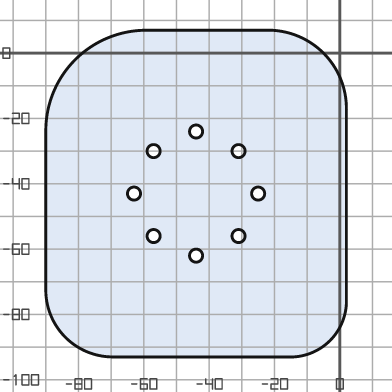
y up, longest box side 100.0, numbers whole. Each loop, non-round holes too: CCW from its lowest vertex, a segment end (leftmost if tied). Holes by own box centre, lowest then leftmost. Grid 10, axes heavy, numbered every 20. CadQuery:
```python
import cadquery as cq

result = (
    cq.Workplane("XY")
    .moveTo(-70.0, -93.0)
    .lineTo(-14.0, -93.0)
    .threePointArc((-3.0, -88.0), (2.0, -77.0))
    .lineTo(2.0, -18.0)
    .threePointArc((-5.0, 0.0), (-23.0, 7.0))
    .lineTo(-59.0, 7.0)
    .threePointArc((-81.0, -2.0), (-90.0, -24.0))
    .lineTo(-90.0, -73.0)
    .threePointArc((-84.0, -87.0), (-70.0, -93.0))
    .close()
    .moveTo(-44.0, -62.0)
    .circle(2.0)
    .moveTo(-57.0, -56.0)
    .circle(2.0)
    .moveTo(-31.0, -56.0)
    .circle(2.0)
    .moveTo(-63.0, -43.0)
    .circle(2.0)
    .moveTo(-25.0, -43.0)
    .circle(2.0)
    .moveTo(-57.0, -30.0)
    .circle(2.0)
    .moveTo(-31.0, -30.0)
    .circle(2.0)
    .moveTo(-44.0, -24.0)
    .circle(2.0)
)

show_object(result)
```